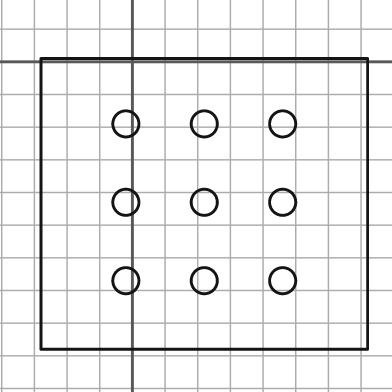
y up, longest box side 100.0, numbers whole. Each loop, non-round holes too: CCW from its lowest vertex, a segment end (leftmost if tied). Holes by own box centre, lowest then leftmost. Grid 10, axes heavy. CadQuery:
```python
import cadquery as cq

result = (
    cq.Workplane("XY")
    .moveTo(-28.0, -88.0)
    .lineTo(72.0, -88.0)
    .lineTo(72.0, 1.0)
    .lineTo(-28.0, 1.0)
    .close()
    .moveTo(-2.0, -67.0)
    .circle(4.0)
    .moveTo(22.0, -67.0)
    .circle(4.0)
    .moveTo(46.0, -67.0)
    .circle(4.0)
    .moveTo(-2.0, -43.0)
    .circle(4.0)
    .moveTo(22.0, -43.0)
    .circle(4.0)
    .moveTo(46.0, -43.0)
    .circle(4.0)
    .moveTo(-2.0, -19.0)
    .circle(4.0)
    .moveTo(22.0, -19.0)
    .circle(4.0)
    .moveTo(46.0, -19.0)
    .circle(4.0)
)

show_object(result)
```